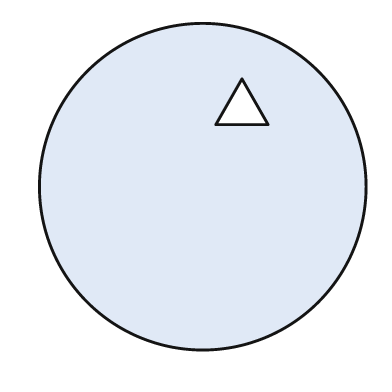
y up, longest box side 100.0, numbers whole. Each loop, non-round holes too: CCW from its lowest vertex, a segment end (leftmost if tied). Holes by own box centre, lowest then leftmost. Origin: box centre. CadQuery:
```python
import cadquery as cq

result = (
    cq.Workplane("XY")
    .moveTo(0.0, 0.0)
    .circle(50.0)
    .moveTo(4.0, 19.0)
    .lineTo(20.0, 19.0)
    .lineTo(12.0, 33.0)
    .close()
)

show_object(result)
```